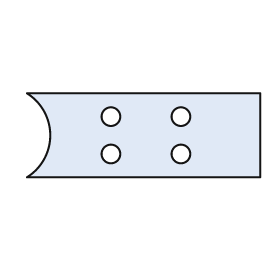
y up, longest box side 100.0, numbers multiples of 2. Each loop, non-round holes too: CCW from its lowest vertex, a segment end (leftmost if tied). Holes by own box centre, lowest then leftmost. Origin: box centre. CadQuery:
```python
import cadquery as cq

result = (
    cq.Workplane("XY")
    .moveTo(-50.0, -18.0)
    .lineTo(50.0, -18.0)
    .lineTo(50.0, 18.0)
    .lineTo(-50.0, 18.0)
    .threePointArc((-40.0, 0.0), (-50.0, -18.0))
    .close()
    .moveTo(-14.0, -8.0)
    .circle(4.0)
    .moveTo(16.0, -8.0)
    .circle(4.0)
    .moveTo(-14.0, 8.0)
    .circle(4.0)
    .moveTo(16.0, 8.0)
    .circle(4.0)
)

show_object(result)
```